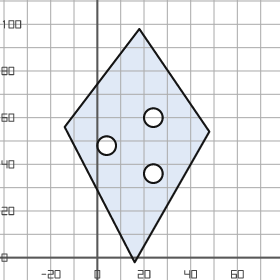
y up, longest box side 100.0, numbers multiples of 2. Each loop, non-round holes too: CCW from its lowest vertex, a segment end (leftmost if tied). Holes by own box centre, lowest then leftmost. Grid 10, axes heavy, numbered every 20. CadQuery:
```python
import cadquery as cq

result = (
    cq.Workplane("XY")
    .moveTo(16.0, -2.0)
    .lineTo(48.0, 54.0)
    .lineTo(18.0, 98.0)
    .lineTo(-14.0, 56.0)
    .close()
    .moveTo(24.0, 36.0)
    .circle(4.0)
    .moveTo(4.0, 48.0)
    .circle(4.0)
    .moveTo(24.0, 60.0)
    .circle(4.0)
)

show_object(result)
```